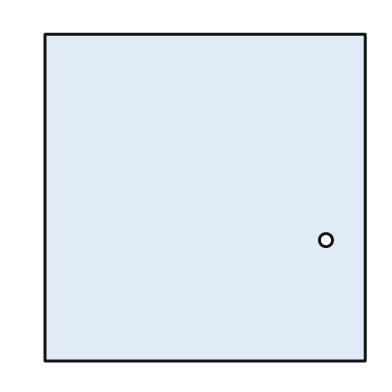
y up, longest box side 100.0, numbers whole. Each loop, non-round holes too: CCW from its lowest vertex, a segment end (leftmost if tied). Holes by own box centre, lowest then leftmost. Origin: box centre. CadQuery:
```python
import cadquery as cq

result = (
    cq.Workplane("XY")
    .moveTo(-49.0, -50.0)
    .lineTo(49.0, -50.0)
    .lineTo(49.0, 50.0)
    .lineTo(-49.0, 50.0)
    .close()
    .moveTo(37.0, -13.0)
    .circle(2.0)
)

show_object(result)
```